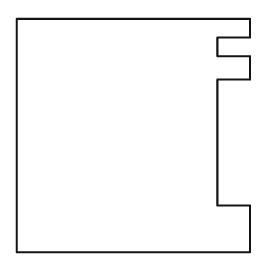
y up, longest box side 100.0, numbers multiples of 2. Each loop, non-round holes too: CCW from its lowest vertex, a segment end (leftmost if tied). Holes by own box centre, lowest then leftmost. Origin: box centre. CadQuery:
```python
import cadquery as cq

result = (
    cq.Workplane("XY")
    .moveTo(-50.0, -50.0)
    .lineTo(50.0, -50.0)
    .lineTo(50.0, -30.0)
    .lineTo(36.0, -30.0)
    .lineTo(36.0, 24.0)
    .lineTo(50.0, 24.0)
    .lineTo(50.0, 34.0)
    .lineTo(36.0, 34.0)
    .lineTo(36.0, 42.0)
    .lineTo(50.0, 42.0)
    .lineTo(50.0, 50.0)
    .lineTo(-50.0, 50.0)
    .close()
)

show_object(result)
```